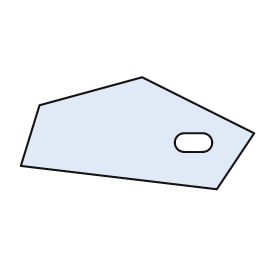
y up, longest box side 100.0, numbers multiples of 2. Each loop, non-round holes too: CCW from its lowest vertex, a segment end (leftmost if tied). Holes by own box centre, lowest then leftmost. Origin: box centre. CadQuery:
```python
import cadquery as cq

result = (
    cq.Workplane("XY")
    .moveTo(34.0, -24.0)
    .lineTo(50.0, 0.0)
    .lineTo(2.0, 24.0)
    .lineTo(-42.0, 12.0)
    .lineTo(-50.0, -14.0)
    .close()
    .moveTo(20.0, -8.0)
    .lineTo(28.0, -8.0)
    .threePointArc((32.0, -4.0), (28.0, 0.0))
    .lineTo(20.0, 0.0)
    .threePointArc((16.0, -4.0), (20.0, -8.0))
    .close()
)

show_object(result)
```